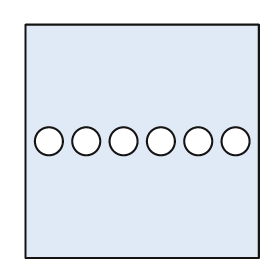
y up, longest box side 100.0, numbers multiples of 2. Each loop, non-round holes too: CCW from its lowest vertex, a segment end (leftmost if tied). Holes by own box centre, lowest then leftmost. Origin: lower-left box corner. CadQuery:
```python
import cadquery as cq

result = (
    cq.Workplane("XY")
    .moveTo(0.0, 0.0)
    .lineTo(100.0, 0.0)
    .lineTo(100.0, 100.0)
    .lineTo(0.0, 100.0)
    .close()
    .moveTo(10.0, 50.0)
    .circle(6.0)
    .moveTo(26.0, 50.0)
    .circle(6.0)
    .moveTo(42.0, 50.0)
    .circle(6.0)
    .moveTo(58.0, 50.0)
    .circle(6.0)
    .moveTo(74.0, 50.0)
    .circle(6.0)
    .moveTo(90.0, 50.0)
    .circle(6.0)
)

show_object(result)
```